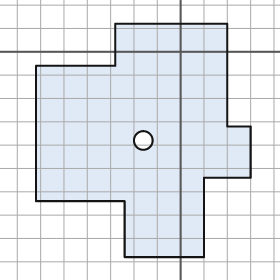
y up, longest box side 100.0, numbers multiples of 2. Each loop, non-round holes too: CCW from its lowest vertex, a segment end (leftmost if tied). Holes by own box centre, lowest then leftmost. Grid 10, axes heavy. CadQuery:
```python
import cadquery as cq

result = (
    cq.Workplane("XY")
    .moveTo(-24.0, -88.0)
    .lineTo(10.0, -88.0)
    .lineTo(10.0, -54.0)
    .lineTo(30.0, -54.0)
    .lineTo(30.0, -32.0)
    .lineTo(20.0, -32.0)
    .lineTo(20.0, 12.0)
    .lineTo(-28.0, 12.0)
    .lineTo(-28.0, -6.0)
    .lineTo(-62.0, -6.0)
    .lineTo(-62.0, -64.0)
    .lineTo(-24.0, -64.0)
    .close()
    .moveTo(-16.0, -38.0)
    .circle(4.0)
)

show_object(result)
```